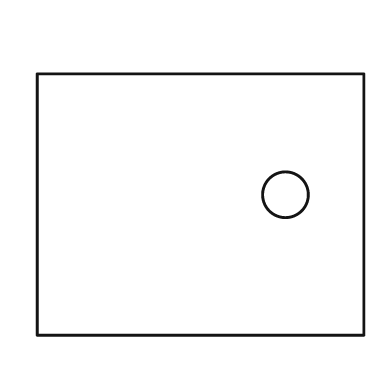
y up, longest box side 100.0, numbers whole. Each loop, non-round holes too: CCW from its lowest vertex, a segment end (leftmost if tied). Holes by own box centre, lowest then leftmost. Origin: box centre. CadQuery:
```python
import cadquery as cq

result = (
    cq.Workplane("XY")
    .moveTo(-50.0, -40.0)
    .lineTo(50.0, -40.0)
    .lineTo(50.0, 40.0)
    .lineTo(-50.0, 40.0)
    .close()
    .moveTo(26.0, 3.0)
    .circle(7.0)
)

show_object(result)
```